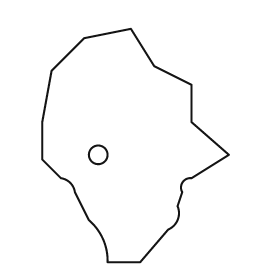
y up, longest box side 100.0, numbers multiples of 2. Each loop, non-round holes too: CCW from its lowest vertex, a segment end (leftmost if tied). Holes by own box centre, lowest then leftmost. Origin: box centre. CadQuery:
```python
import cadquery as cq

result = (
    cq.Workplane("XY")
    .moveTo(-12.0, -50.0)
    .lineTo(2.0, -50.0)
    .lineTo(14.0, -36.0)
    .threePointArc((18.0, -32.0), (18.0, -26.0))
    .lineTo(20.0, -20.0)
    .threePointArc((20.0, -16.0), (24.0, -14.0))
    .lineTo(40.0, -4.0)
    .lineTo(24.0, 10.0)
    .lineTo(24.0, 26.0)
    .lineTo(8.0, 34.0)
    .lineTo(-2.0, 50.0)
    .lineTo(-22.0, 46.0)
    .lineTo(-36.0, 32.0)
    .lineTo(-40.0, 10.0)
    .lineTo(-40.0, -6.0)
    .lineTo(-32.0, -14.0)
    .threePointArc((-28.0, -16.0), (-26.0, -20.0))
    .lineTo(-20.0, -32.0)
    .threePointArc((-14.0, -40.0), (-12.0, -50.0))
    .close()
    .moveTo(-16.0, -4.0)
    .circle(4.0)
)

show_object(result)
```